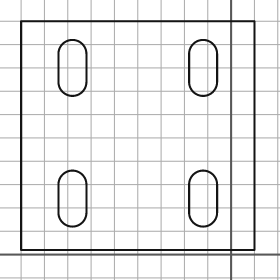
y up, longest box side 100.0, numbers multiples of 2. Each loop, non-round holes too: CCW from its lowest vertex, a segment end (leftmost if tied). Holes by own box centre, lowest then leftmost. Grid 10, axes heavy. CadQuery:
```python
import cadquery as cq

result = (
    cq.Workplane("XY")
    .moveTo(-90.0, 2.0)
    .lineTo(10.0, 2.0)
    .lineTo(10.0, 100.0)
    .lineTo(-90.0, 100.0)
    .close()
    .moveTo(-74.0, 18.0)
    .threePointArc((-68.0, 12.0), (-62.0, 18.0))
    .lineTo(-62.0, 30.0)
    .threePointArc((-68.0, 36.0), (-74.0, 30.0))
    .close()
    .moveTo(-18.0, 18.0)
    .threePointArc((-12.0, 12.0), (-6.0, 18.0))
    .lineTo(-6.0, 30.0)
    .threePointArc((-12.0, 36.0), (-18.0, 30.0))
    .close()
    .moveTo(-74.0, 74.0)
    .threePointArc((-68.0, 68.0), (-62.0, 74.0))
    .lineTo(-62.0, 86.0)
    .threePointArc((-68.0, 92.0), (-74.0, 86.0))
    .close()
    .moveTo(-18.0, 74.0)
    .threePointArc((-12.0, 68.0), (-6.0, 74.0))
    .lineTo(-6.0, 86.0)
    .threePointArc((-12.0, 92.0), (-18.0, 86.0))
    .close()
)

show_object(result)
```